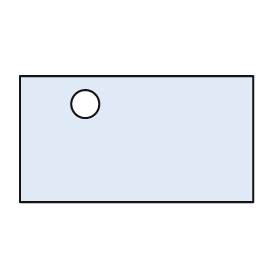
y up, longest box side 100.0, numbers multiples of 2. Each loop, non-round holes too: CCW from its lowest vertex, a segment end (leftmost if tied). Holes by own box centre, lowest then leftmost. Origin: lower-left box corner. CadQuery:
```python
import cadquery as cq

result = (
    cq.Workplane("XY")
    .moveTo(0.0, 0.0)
    .lineTo(100.0, 0.0)
    .lineTo(100.0, 54.0)
    .lineTo(0.0, 54.0)
    .close()
    .moveTo(28.0, 42.0)
    .circle(6.0)
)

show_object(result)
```